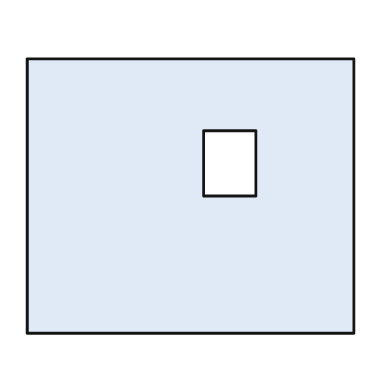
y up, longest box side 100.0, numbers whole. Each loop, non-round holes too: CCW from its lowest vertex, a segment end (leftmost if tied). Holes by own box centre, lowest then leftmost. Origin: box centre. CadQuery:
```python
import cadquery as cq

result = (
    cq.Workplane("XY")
    .moveTo(-50.0, -42.0)
    .lineTo(50.0, -42.0)
    .lineTo(50.0, 42.0)
    .lineTo(-50.0, 42.0)
    .close()
    .moveTo(4.0, 0.0)
    .lineTo(20.0, 0.0)
    .lineTo(20.0, 20.0)
    .lineTo(4.0, 20.0)
    .close()
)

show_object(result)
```